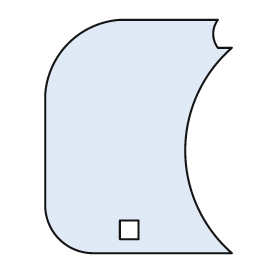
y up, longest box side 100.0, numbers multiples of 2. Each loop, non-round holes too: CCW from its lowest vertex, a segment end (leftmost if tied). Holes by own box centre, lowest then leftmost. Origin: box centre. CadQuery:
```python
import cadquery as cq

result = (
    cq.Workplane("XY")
    .moveTo(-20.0, -50.0)
    .lineTo(40.0, -50.0)
    .threePointArc((20.0, -6.0), (40.0, 38.0))
    .lineTo(34.0, 38.0)
    .threePointArc((32.0, 44.0), (34.0, 50.0))
    .lineTo(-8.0, 50.0)
    .threePointArc((-30.0, 40.0), (-40.0, 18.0))
    .lineTo(-40.0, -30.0)
    .threePointArc((-34.0, -44.0), (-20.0, -50.0))
    .close()
    .moveTo(-8.0, -44.0)
    .lineTo(0.0, -44.0)
    .lineTo(0.0, -36.0)
    .lineTo(-8.0, -36.0)
    .close()
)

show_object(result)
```